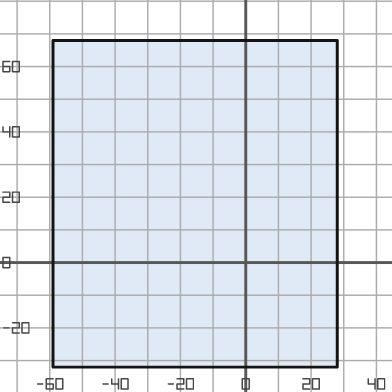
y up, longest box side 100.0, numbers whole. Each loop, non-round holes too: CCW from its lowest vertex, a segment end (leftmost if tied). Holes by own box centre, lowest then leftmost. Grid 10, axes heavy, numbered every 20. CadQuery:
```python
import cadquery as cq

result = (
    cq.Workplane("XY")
    .moveTo(-59.0, -32.0)
    .lineTo(28.0, -32.0)
    .lineTo(28.0, 68.0)
    .lineTo(-59.0, 68.0)
    .close()
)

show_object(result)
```